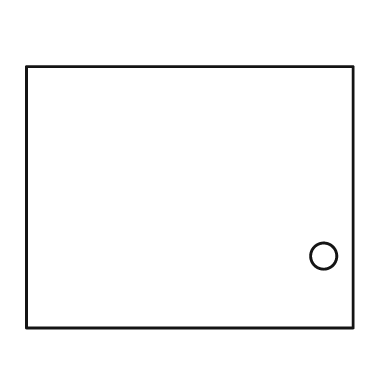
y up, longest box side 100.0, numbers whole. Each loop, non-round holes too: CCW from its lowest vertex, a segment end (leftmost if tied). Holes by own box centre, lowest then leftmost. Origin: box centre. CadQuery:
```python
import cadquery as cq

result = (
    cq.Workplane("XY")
    .moveTo(-50.0, -40.0)
    .lineTo(50.0, -40.0)
    .lineTo(50.0, 40.0)
    .lineTo(-50.0, 40.0)
    .close()
    .moveTo(41.0, -18.0)
    .circle(4.0)
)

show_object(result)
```